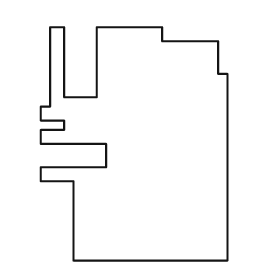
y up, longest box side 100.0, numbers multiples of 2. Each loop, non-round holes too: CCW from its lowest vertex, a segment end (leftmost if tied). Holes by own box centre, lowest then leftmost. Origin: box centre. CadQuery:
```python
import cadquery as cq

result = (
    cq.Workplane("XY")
    .moveTo(-26.0, -50.0)
    .lineTo(40.0, -50.0)
    .lineTo(40.0, 30.0)
    .lineTo(36.0, 30.0)
    .lineTo(36.0, 44.0)
    .lineTo(12.0, 44.0)
    .lineTo(12.0, 50.0)
    .lineTo(-16.0, 50.0)
    .lineTo(-16.0, 20.0)
    .lineTo(-30.0, 20.0)
    .lineTo(-30.0, 50.0)
    .lineTo(-36.0, 50.0)
    .lineTo(-36.0, 16.0)
    .lineTo(-40.0, 16.0)
    .lineTo(-40.0, 10.0)
    .lineTo(-30.0, 10.0)
    .lineTo(-30.0, 6.0)
    .lineTo(-40.0, 6.0)
    .lineTo(-40.0, 0.0)
    .lineTo(-12.0, 0.0)
    .lineTo(-12.0, -10.0)
    .lineTo(-40.0, -10.0)
    .lineTo(-40.0, -16.0)
    .lineTo(-26.0, -16.0)
    .close()
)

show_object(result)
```